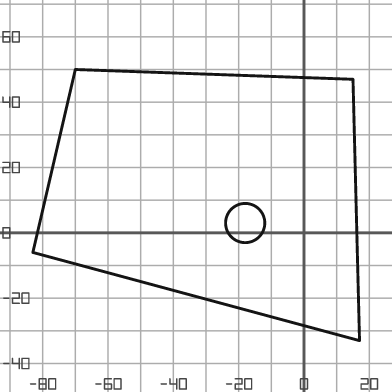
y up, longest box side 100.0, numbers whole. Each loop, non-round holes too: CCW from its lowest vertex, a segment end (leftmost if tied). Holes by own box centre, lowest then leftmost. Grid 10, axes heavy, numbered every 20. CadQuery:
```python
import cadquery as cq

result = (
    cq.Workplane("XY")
    .moveTo(17.0, -33.0)
    .lineTo(15.0, 47.0)
    .lineTo(-70.0, 50.0)
    .lineTo(-83.0, -6.0)
    .close()
    .moveTo(-18.0, 3.0)
    .circle(6.0)
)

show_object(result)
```